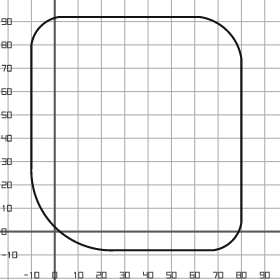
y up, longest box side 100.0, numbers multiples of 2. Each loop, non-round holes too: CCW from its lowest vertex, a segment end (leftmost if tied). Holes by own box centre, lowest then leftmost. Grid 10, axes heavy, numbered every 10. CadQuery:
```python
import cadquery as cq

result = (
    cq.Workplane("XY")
    .moveTo(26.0, -8.0)
    .lineTo(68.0, -8.0)
    .threePointArc((76.0, -4.0), (80.0, 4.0))
    .lineTo(80.0, 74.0)
    .threePointArc((74.0, 86.0), (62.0, 92.0))
    .lineTo(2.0, 92.0)
    .threePointArc((-6.0, 88.0), (-10.0, 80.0))
    .lineTo(-10.0, 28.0)
    .threePointArc((0.0, 2.0), (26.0, -8.0))
    .close()
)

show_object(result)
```